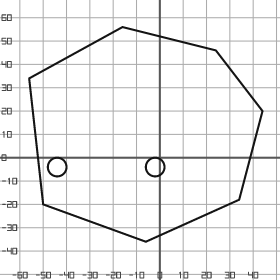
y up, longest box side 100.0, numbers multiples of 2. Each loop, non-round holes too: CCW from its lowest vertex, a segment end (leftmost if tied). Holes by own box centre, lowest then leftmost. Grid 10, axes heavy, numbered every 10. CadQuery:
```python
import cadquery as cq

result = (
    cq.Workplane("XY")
    .moveTo(-6.0, -36.0)
    .lineTo(34.0, -18.0)
    .lineTo(44.0, 20.0)
    .lineTo(24.0, 46.0)
    .lineTo(-16.0, 56.0)
    .lineTo(-56.0, 34.0)
    .lineTo(-50.0, -20.0)
    .close()
    .moveTo(-44.0, -4.0)
    .circle(4.0)
    .moveTo(-2.0, -4.0)
    .circle(4.0)
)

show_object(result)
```